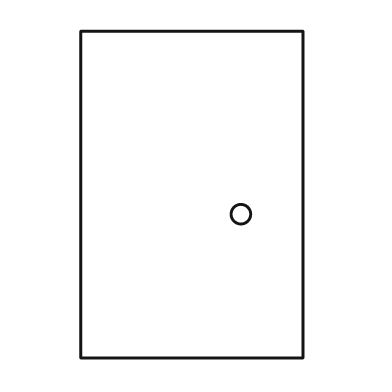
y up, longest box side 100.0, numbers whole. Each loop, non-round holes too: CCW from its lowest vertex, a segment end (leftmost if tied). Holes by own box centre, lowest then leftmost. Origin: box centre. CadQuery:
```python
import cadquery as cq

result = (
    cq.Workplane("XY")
    .moveTo(-34.0, -50.0)
    .lineTo(34.0, -50.0)
    .lineTo(34.0, 50.0)
    .lineTo(-34.0, 50.0)
    .close()
    .moveTo(15.0, -6.0)
    .circle(3.0)
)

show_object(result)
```